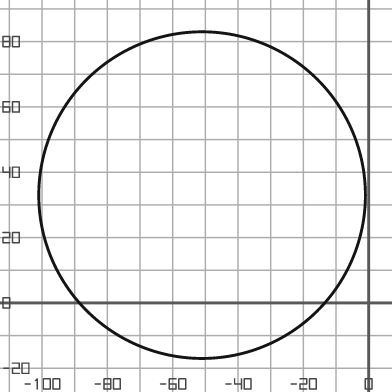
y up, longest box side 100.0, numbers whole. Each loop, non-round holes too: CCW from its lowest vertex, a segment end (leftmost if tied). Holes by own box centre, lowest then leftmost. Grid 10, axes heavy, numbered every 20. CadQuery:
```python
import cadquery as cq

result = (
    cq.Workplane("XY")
    .moveTo(-51.0, 33.0)
    .circle(50.0)
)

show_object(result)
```